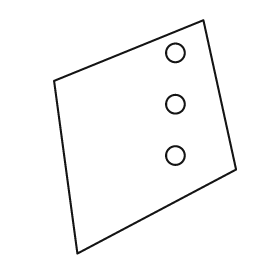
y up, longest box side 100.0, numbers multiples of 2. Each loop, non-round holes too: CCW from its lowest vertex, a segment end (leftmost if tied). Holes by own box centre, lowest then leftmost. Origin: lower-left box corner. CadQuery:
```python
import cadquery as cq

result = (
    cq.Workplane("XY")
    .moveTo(10.0, 0.0)
    .lineTo(78.0, 36.0)
    .lineTo(64.0, 100.0)
    .lineTo(0.0, 74.0)
    .close()
    .moveTo(52.0, 42.0)
    .circle(4.0)
    .moveTo(52.0, 64.0)
    .circle(4.0)
    .moveTo(52.0, 86.0)
    .circle(4.0)
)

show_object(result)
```